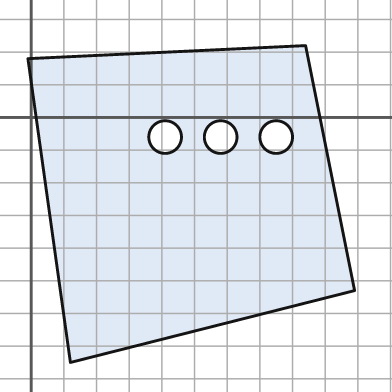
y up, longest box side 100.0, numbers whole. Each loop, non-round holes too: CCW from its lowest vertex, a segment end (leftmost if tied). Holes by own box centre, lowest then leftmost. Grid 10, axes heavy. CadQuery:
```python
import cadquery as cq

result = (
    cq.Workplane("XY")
    .moveTo(12.0, -75.0)
    .lineTo(99.0, -53.0)
    .lineTo(84.0, 22.0)
    .lineTo(-1.0, 18.0)
    .close()
    .moveTo(41.0, -6.0)
    .circle(5.0)
    .moveTo(58.0, -6.0)
    .circle(5.0)
    .moveTo(75.0, -6.0)
    .circle(5.0)
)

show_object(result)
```